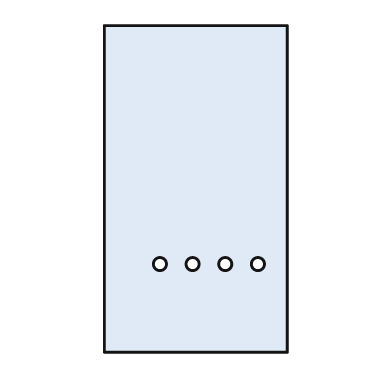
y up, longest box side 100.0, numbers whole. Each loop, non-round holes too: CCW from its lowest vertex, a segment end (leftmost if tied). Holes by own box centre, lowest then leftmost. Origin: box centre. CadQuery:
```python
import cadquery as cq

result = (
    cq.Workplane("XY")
    .moveTo(-28.0, -50.0)
    .lineTo(28.0, -50.0)
    .lineTo(28.0, 50.0)
    .lineTo(-28.0, 50.0)
    .close()
    .moveTo(-11.0, -23.0)
    .circle(2.0)
    .moveTo(-1.0, -23.0)
    .circle(2.0)
    .moveTo(9.0, -23.0)
    .circle(2.0)
    .moveTo(19.0, -23.0)
    .circle(2.0)
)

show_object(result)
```